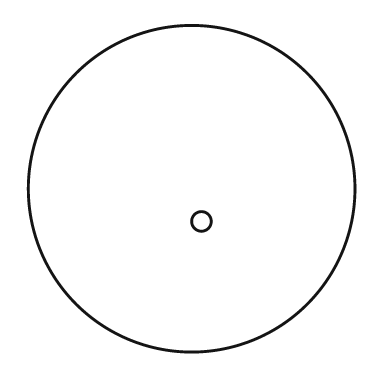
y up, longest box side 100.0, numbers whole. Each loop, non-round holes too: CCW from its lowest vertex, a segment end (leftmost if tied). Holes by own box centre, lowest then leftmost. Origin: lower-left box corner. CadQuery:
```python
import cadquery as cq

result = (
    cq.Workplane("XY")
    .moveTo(50.0, 50.0)
    .circle(50.0)
    .moveTo(53.0, 40.0)
    .circle(3.0)
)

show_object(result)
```